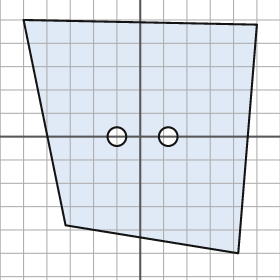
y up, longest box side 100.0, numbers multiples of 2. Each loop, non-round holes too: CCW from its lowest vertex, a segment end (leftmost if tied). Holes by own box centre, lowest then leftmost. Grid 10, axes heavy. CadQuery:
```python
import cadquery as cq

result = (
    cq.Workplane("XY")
    .moveTo(42.0, -50.0)
    .lineTo(50.0, 48.0)
    .lineTo(-50.0, 50.0)
    .lineTo(-32.0, -38.0)
    .close()
    .moveTo(-10.0, 0.0)
    .circle(4.0)
    .moveTo(12.0, 0.0)
    .circle(4.0)
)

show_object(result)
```